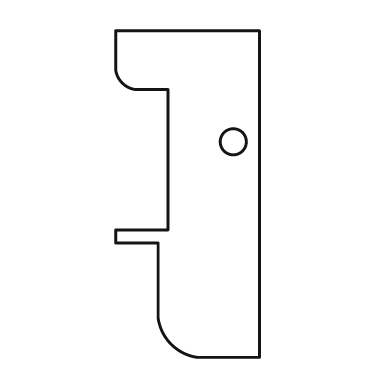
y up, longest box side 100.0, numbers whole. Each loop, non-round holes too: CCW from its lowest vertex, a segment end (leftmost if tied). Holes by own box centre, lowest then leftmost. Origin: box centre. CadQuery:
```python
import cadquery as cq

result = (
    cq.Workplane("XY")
    .moveTo(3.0, -50.0)
    .lineTo(22.0, -50.0)
    .lineTo(22.0, 50.0)
    .lineTo(-22.0, 50.0)
    .lineTo(-22.0, 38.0)
    .threePointArc((-20.0, 34.0), (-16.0, 32.0))
    .lineTo(-6.0, 32.0)
    .lineTo(-6.0, -11.0)
    .lineTo(-22.0, -11.0)
    .lineTo(-22.0, -15.0)
    .lineTo(-9.0, -15.0)
    .lineTo(-9.0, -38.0)
    .threePointArc((-5.0, -46.0), (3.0, -50.0))
    .close()
    .moveTo(14.0, 16.0)
    .circle(4.0)
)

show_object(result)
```